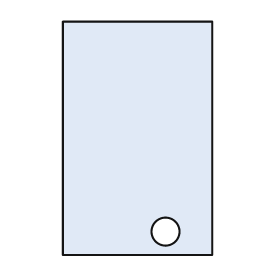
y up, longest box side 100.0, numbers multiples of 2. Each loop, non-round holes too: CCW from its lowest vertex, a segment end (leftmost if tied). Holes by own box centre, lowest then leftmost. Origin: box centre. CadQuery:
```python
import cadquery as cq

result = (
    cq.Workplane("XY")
    .moveTo(-32.0, -50.0)
    .lineTo(32.0, -50.0)
    .lineTo(32.0, 50.0)
    .lineTo(-32.0, 50.0)
    .close()
    .moveTo(12.0, -40.0)
    .circle(6.0)
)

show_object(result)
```